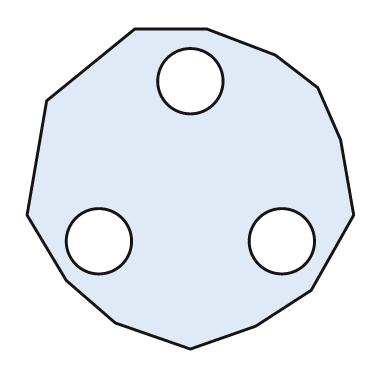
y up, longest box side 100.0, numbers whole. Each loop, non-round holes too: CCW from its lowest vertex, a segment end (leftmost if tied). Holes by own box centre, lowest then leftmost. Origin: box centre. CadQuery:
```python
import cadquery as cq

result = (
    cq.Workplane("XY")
    .moveTo(0.0, -49.0)
    .lineTo(20.0, -42.0)
    .lineTo(37.0, -31.0)
    .lineTo(50.0, -8.0)
    .lineTo(46.0, 15.0)
    .lineTo(39.0, 31.0)
    .lineTo(26.0, 41.0)
    .lineTo(5.0, 49.0)
    .lineTo(-17.0, 49.0)
    .lineTo(-44.0, 27.0)
    .lineTo(-50.0, -8.0)
    .lineTo(-38.0, -28.0)
    .lineTo(-23.0, -41.0)
    .close()
    .moveTo(-28.0, -16.0)
    .circle(10.0)
    .moveTo(28.0, -16.0)
    .circle(10.0)
    .moveTo(0.0, 33.0)
    .circle(10.0)
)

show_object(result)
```